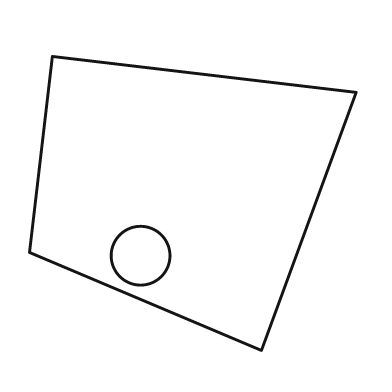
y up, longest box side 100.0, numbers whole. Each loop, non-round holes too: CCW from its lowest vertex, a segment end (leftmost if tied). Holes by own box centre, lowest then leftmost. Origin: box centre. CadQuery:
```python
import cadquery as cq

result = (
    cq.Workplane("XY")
    .moveTo(21.0, -45.0)
    .lineTo(50.0, 34.0)
    .lineTo(-43.0, 45.0)
    .lineTo(-50.0, -15.0)
    .close()
    .moveTo(-16.0, -16.0)
    .circle(9.0)
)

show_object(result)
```